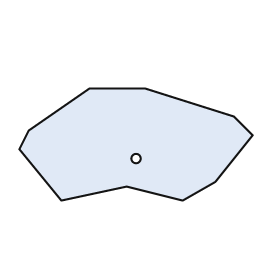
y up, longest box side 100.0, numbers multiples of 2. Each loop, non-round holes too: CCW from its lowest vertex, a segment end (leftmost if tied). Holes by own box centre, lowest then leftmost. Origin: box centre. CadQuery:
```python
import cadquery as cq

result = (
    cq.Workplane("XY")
    .moveTo(-32.0, -24.0)
    .lineTo(-4.0, -18.0)
    .lineTo(20.0, -24.0)
    .lineTo(34.0, -16.0)
    .lineTo(50.0, 4.0)
    .lineTo(42.0, 12.0)
    .lineTo(4.0, 24.0)
    .lineTo(-20.0, 24.0)
    .lineTo(-46.0, 6.0)
    .lineTo(-50.0, -2.0)
    .close()
    .moveTo(0.0, -6.0)
    .circle(2.0)
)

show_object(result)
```